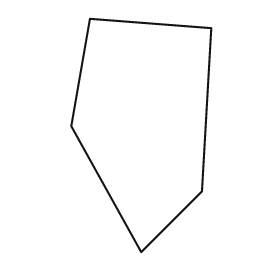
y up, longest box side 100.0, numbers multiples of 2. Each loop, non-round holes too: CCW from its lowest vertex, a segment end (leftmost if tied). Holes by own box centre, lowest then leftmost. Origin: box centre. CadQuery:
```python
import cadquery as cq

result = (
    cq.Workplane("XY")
    .moveTo(0.0, -50.0)
    .lineTo(26.0, -24.0)
    .lineTo(30.0, 46.0)
    .lineTo(-22.0, 50.0)
    .lineTo(-30.0, 4.0)
    .close()
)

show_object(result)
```